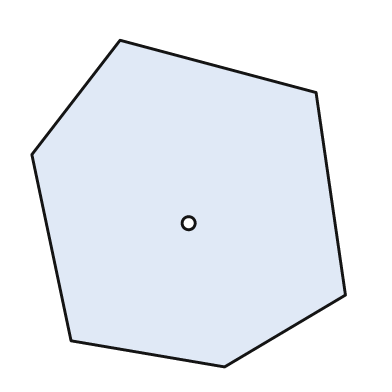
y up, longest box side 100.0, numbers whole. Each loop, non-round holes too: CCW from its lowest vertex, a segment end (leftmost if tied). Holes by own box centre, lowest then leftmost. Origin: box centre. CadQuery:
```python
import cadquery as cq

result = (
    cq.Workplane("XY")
    .moveTo(11.0, -50.0)
    .lineTo(48.0, -28.0)
    .lineTo(39.0, 34.0)
    .lineTo(-21.0, 50.0)
    .lineTo(-48.0, 15.0)
    .lineTo(-36.0, -42.0)
    .close()
    .moveTo(0.0, -6.0)
    .circle(2.0)
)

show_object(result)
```